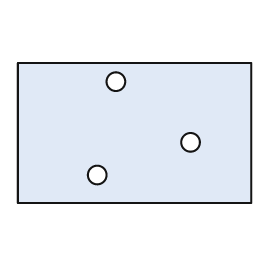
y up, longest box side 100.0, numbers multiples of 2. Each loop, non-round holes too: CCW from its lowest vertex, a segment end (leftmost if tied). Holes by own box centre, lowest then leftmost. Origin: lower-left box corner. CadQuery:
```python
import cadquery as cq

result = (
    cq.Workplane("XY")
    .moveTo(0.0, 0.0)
    .lineTo(100.0, 0.0)
    .lineTo(100.0, 60.0)
    .lineTo(0.0, 60.0)
    .close()
    .moveTo(34.0, 12.0)
    .circle(4.0)
    .moveTo(74.0, 26.0)
    .circle(4.0)
    .moveTo(42.0, 52.0)
    .circle(4.0)
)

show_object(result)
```